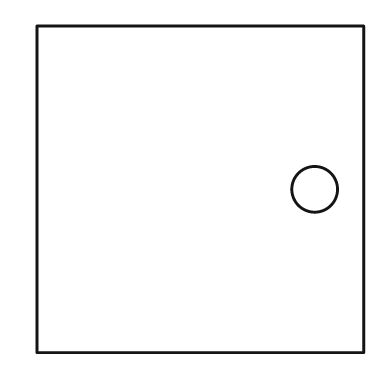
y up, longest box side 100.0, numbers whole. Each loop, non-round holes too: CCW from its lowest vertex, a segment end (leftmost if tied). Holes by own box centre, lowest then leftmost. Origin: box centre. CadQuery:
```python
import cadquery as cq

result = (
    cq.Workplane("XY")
    .moveTo(-50.0, -50.0)
    .lineTo(50.0, -50.0)
    .lineTo(50.0, 50.0)
    .lineTo(-50.0, 50.0)
    .close()
    .moveTo(35.0, 0.0)
    .circle(7.0)
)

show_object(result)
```